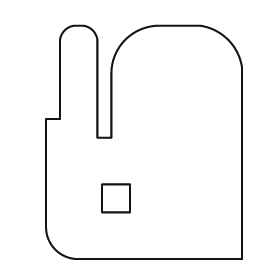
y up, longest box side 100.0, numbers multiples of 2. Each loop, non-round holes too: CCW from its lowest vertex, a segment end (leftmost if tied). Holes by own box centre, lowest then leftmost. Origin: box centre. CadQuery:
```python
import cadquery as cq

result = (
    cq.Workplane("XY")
    .moveTo(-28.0, -50.0)
    .lineTo(42.0, -50.0)
    .lineTo(42.0, 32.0)
    .threePointArc((36.0, 44.0), (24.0, 50.0))
    .lineTo(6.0, 50.0)
    .threePointArc((-8.0, 44.0), (-14.0, 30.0))
    .lineTo(-14.0, 2.0)
    .lineTo(-20.0, 2.0)
    .lineTo(-20.0, 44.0)
    .threePointArc((-22.0, 48.0), (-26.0, 50.0))
    .lineTo(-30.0, 50.0)
    .threePointArc((-34.0, 48.0), (-36.0, 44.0))
    .lineTo(-36.0, 10.0)
    .lineTo(-42.0, 10.0)
    .lineTo(-42.0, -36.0)
    .threePointArc((-38.0, -46.0), (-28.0, -50.0))
    .close()
    .moveTo(-18.0, -30.0)
    .lineTo(-6.0, -30.0)
    .lineTo(-6.0, -18.0)
    .lineTo(-18.0, -18.0)
    .close()
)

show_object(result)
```